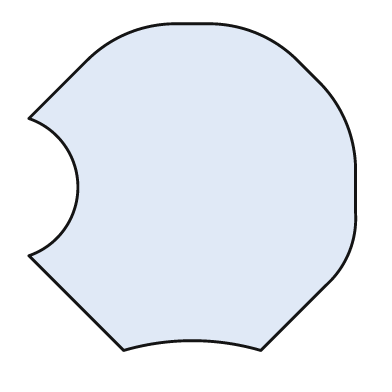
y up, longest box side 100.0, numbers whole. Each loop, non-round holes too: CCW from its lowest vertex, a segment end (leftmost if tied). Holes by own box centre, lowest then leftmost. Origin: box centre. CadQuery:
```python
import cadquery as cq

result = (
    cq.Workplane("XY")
    .moveTo(-21.0, -50.0)
    .threePointArc((0.0, -47.0), (21.0, -50.0))
    .lineTo(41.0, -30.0)
    .threePointArc((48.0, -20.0), (50.0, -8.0))
    .lineTo(50.0, 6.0)
    .threePointArc((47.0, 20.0), (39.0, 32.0))
    .lineTo(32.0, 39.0)
    .threePointArc((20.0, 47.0), (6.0, 50.0))
    .lineTo(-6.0, 50.0)
    .threePointArc((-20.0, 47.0), (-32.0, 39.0))
    .lineTo(-50.0, 21.0)
    .threePointArc((-35.0, 0.0), (-50.0, -21.0))
    .close()
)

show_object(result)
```